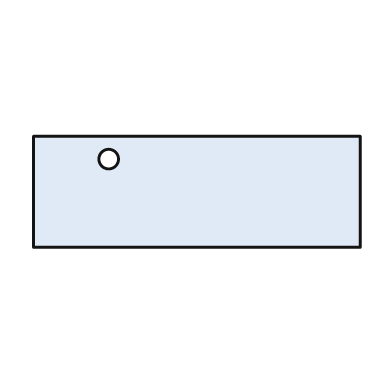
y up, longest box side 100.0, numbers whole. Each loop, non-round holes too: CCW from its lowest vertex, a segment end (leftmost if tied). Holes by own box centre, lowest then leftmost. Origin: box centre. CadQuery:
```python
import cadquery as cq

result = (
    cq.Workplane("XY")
    .moveTo(-50.0, -17.0)
    .lineTo(50.0, -17.0)
    .lineTo(50.0, 17.0)
    .lineTo(-50.0, 17.0)
    .close()
    .moveTo(-27.0, 10.0)
    .circle(3.0)
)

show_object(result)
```